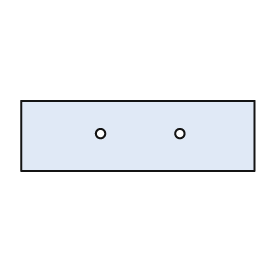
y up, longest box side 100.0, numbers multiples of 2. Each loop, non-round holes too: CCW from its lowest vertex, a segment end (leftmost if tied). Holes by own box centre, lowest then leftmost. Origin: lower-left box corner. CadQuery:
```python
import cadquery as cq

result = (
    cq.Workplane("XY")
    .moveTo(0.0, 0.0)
    .lineTo(100.0, 0.0)
    .lineTo(100.0, 30.0)
    .lineTo(0.0, 30.0)
    .close()
    .moveTo(34.0, 16.0)
    .circle(2.0)
    .moveTo(68.0, 16.0)
    .circle(2.0)
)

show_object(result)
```